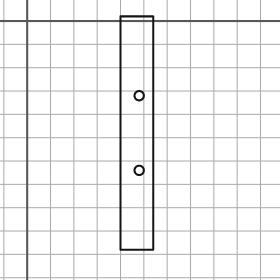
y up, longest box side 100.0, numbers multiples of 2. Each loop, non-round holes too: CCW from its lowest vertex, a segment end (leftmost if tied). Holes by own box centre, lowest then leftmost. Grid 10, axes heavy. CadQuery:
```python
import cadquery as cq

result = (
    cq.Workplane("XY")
    .moveTo(40.0, -98.0)
    .lineTo(54.0, -98.0)
    .lineTo(54.0, 2.0)
    .lineTo(40.0, 2.0)
    .close()
    .moveTo(48.0, -64.0)
    .circle(2.0)
    .moveTo(48.0, -32.0)
    .circle(2.0)
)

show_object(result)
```